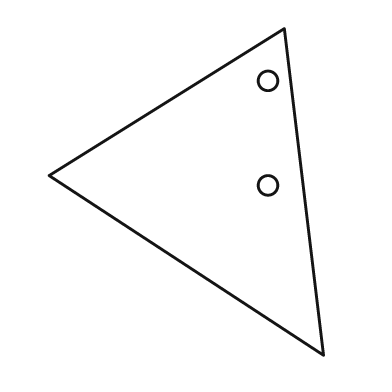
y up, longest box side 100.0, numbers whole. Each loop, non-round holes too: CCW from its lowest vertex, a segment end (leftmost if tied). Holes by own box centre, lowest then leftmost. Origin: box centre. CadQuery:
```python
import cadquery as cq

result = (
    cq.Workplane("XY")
    .moveTo(42.0, -50.0)
    .lineTo(30.0, 50.0)
    .lineTo(-42.0, 5.0)
    .close()
    .moveTo(25.0, 2.0)
    .circle(3.0)
    .moveTo(25.0, 34.0)
    .circle(3.0)
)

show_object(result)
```